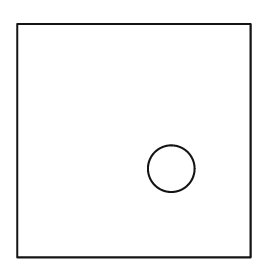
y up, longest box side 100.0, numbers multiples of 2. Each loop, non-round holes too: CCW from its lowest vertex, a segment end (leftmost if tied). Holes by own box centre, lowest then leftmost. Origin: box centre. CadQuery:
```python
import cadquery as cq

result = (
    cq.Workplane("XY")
    .moveTo(-50.0, -50.0)
    .lineTo(50.0, -50.0)
    .lineTo(50.0, 50.0)
    .lineTo(-50.0, 50.0)
    .close()
    .moveTo(16.0, -12.0)
    .circle(10.0)
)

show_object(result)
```